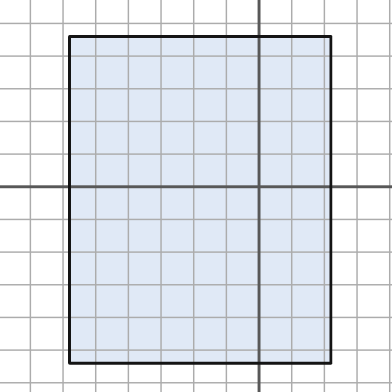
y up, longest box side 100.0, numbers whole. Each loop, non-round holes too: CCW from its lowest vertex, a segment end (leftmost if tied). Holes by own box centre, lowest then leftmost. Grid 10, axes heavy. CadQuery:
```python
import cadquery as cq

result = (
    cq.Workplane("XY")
    .moveTo(-58.0, -54.0)
    .lineTo(22.0, -54.0)
    .lineTo(22.0, 46.0)
    .lineTo(-58.0, 46.0)
    .close()
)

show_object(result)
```